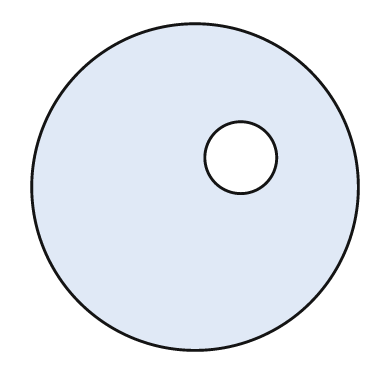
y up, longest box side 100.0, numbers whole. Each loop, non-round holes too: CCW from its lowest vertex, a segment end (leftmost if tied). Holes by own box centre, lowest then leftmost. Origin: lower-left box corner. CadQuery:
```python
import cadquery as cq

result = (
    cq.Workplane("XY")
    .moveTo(50.0, 50.0)
    .circle(50.0)
    .moveTo(64.0, 59.0)
    .circle(11.0)
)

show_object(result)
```